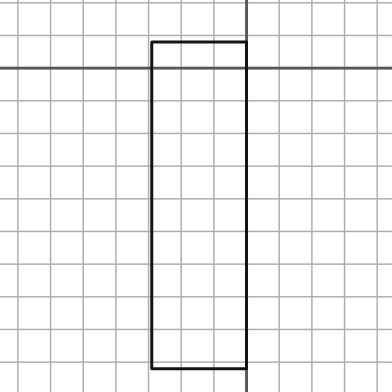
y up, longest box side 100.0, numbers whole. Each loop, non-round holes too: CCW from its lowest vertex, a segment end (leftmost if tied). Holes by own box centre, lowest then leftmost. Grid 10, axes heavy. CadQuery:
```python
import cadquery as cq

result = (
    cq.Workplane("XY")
    .moveTo(-29.0, -92.0)
    .lineTo(0.0, -92.0)
    .lineTo(0.0, 8.0)
    .lineTo(-29.0, 8.0)
    .close()
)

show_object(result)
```